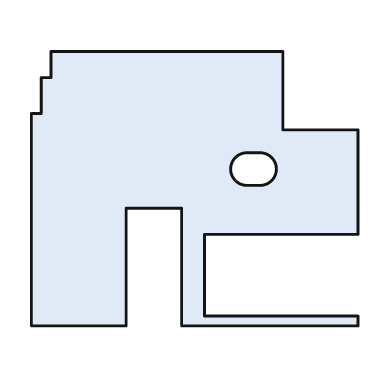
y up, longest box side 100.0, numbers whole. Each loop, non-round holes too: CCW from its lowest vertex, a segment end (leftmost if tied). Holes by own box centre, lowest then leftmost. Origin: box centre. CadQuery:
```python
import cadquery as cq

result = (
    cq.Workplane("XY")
    .moveTo(-50.0, -42.0)
    .lineTo(-21.0, -42.0)
    .lineTo(-21.0, -6.0)
    .lineTo(-4.0, -6.0)
    .lineTo(-4.0, -42.0)
    .lineTo(50.0, -42.0)
    .lineTo(50.0, -39.0)
    .lineTo(3.0, -39.0)
    .lineTo(3.0, -14.0)
    .lineTo(50.0, -14.0)
    .lineTo(50.0, 18.0)
    .lineTo(27.0, 18.0)
    .lineTo(27.0, 42.0)
    .lineTo(-44.0, 42.0)
    .lineTo(-44.0, 34.0)
    .lineTo(-47.0, 34.0)
    .lineTo(-47.0, 23.0)
    .lineTo(-50.0, 23.0)
    .close()
    .moveTo(16.0, 1.0)
    .lineTo(20.0, 1.0)
    .threePointArc((25.0, 6.0), (20.0, 11.0))
    .lineTo(16.0, 11.0)
    .threePointArc((11.0, 6.0), (16.0, 1.0))
    .close()
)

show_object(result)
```